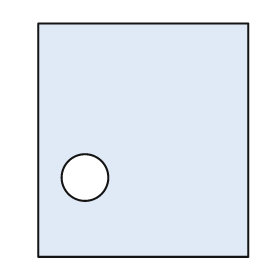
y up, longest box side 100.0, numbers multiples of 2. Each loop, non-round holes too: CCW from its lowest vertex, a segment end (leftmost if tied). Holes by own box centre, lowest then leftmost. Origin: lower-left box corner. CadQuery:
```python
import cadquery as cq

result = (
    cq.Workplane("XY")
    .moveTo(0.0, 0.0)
    .lineTo(90.0, 0.0)
    .lineTo(90.0, 100.0)
    .lineTo(0.0, 100.0)
    .close()
    .moveTo(20.0, 34.0)
    .circle(10.0)
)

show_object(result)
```